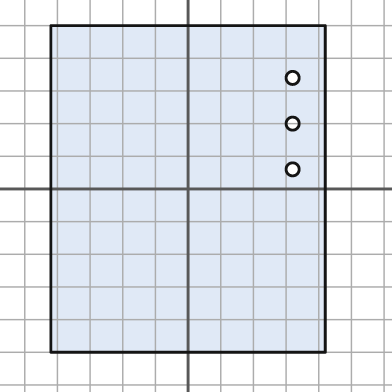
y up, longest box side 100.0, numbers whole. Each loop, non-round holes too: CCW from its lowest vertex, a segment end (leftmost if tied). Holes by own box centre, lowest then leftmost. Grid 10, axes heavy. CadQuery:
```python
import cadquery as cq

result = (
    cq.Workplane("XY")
    .moveTo(-42.0, -50.0)
    .lineTo(42.0, -50.0)
    .lineTo(42.0, 50.0)
    .lineTo(-42.0, 50.0)
    .close()
    .moveTo(32.0, 6.0)
    .circle(2.0)
    .moveTo(32.0, 20.0)
    .circle(2.0)
    .moveTo(32.0, 34.0)
    .circle(2.0)
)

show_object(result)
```